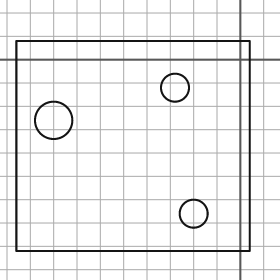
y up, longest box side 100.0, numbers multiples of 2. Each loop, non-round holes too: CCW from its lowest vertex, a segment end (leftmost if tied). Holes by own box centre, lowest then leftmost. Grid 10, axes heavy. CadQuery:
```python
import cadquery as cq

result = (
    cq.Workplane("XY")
    .moveTo(-96.0, -82.0)
    .lineTo(4.0, -82.0)
    .lineTo(4.0, 8.0)
    .lineTo(-96.0, 8.0)
    .close()
    .moveTo(-20.0, -66.0)
    .circle(6.0)
    .moveTo(-80.0, -26.0)
    .circle(8.0)
    .moveTo(-28.0, -12.0)
    .circle(6.0)
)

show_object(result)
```